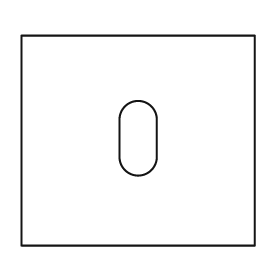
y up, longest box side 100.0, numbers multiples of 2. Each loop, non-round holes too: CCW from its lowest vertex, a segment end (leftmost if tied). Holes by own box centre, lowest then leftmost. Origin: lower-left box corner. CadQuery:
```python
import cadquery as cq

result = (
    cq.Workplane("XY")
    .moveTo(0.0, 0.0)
    .lineTo(100.0, 0.0)
    .lineTo(100.0, 90.0)
    .lineTo(0.0, 90.0)
    .close()
    .moveTo(42.0, 38.0)
    .threePointArc((50.0, 30.0), (58.0, 38.0))
    .lineTo(58.0, 54.0)
    .threePointArc((50.0, 62.0), (42.0, 54.0))
    .close()
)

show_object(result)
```